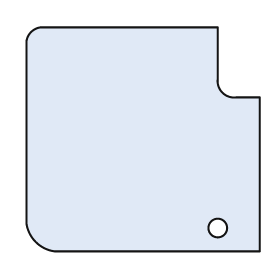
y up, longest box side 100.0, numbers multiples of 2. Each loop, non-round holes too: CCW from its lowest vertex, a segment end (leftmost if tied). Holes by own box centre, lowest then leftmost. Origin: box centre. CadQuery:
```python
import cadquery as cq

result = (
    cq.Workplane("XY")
    .moveTo(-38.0, -48.0)
    .lineTo(50.0, -48.0)
    .lineTo(50.0, 18.0)
    .lineTo(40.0, 18.0)
    .threePointArc((34.0, 20.0), (32.0, 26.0))
    .lineTo(32.0, 48.0)
    .lineTo(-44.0, 48.0)
    .threePointArc((-48.0, 46.0), (-50.0, 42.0))
    .lineTo(-50.0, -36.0)
    .threePointArc((-46.0, -44.0), (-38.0, -48.0))
    .close()
    .moveTo(32.0, -38.0)
    .circle(4.0)
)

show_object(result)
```